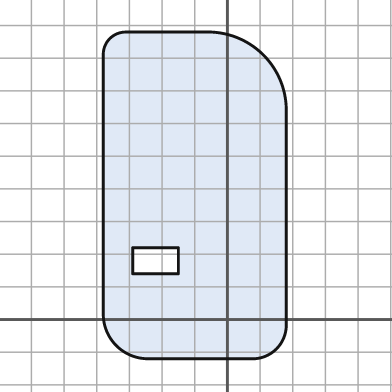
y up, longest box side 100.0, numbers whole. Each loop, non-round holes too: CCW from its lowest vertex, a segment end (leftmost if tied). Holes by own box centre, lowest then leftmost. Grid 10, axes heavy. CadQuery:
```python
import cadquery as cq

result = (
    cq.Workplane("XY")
    .moveTo(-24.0, -12.0)
    .lineTo(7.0, -12.0)
    .threePointArc((15.0, -9.0), (18.0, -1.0))
    .lineTo(18.0, 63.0)
    .threePointArc((11.0, 81.0), (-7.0, 88.0))
    .lineTo(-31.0, 88.0)
    .threePointArc((-36.0, 86.0), (-38.0, 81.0))
    .lineTo(-38.0, 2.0)
    .threePointArc((-34.0, -8.0), (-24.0, -12.0))
    .close()
    .moveTo(-29.0, 14.0)
    .lineTo(-15.0, 14.0)
    .lineTo(-15.0, 22.0)
    .lineTo(-29.0, 22.0)
    .close()
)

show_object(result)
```